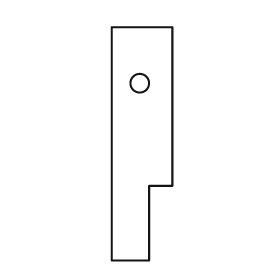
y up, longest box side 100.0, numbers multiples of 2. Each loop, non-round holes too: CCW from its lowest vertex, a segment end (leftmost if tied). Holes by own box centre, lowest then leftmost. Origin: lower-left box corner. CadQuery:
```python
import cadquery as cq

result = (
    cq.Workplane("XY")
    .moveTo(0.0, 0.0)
    .lineTo(16.0, 0.0)
    .lineTo(16.0, 32.0)
    .lineTo(26.0, 32.0)
    .lineTo(26.0, 100.0)
    .lineTo(0.0, 100.0)
    .close()
    .moveTo(12.0, 76.0)
    .circle(4.0)
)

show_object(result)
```